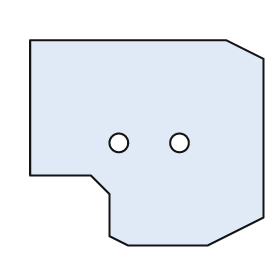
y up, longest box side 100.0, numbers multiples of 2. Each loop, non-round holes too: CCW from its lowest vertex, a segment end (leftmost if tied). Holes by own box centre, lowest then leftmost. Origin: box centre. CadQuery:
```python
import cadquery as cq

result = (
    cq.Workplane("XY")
    .moveTo(-8.0, -44.0)
    .lineTo(26.0, -44.0)
    .lineTo(50.0, -32.0)
    .lineTo(50.0, 36.0)
    .lineTo(34.0, 44.0)
    .lineTo(-50.0, 44.0)
    .lineTo(-50.0, -14.0)
    .lineTo(-24.0, -14.0)
    .lineTo(-16.0, -22.0)
    .lineTo(-16.0, -40.0)
    .close()
    .moveTo(-12.0, 0.0)
    .circle(4.0)
    .moveTo(14.0, 0.0)
    .circle(4.0)
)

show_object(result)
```